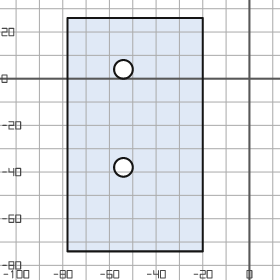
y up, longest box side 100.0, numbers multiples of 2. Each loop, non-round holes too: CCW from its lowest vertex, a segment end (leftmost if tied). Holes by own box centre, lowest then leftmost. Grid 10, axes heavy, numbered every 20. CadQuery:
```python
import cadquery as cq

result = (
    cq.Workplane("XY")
    .moveTo(-78.0, -74.0)
    .lineTo(-20.0, -74.0)
    .lineTo(-20.0, 26.0)
    .lineTo(-78.0, 26.0)
    .close()
    .moveTo(-54.0, -38.0)
    .circle(4.0)
    .moveTo(-54.0, 4.0)
    .circle(4.0)
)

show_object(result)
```